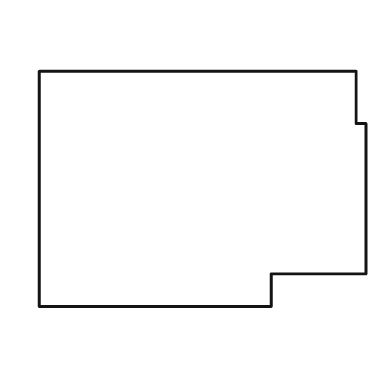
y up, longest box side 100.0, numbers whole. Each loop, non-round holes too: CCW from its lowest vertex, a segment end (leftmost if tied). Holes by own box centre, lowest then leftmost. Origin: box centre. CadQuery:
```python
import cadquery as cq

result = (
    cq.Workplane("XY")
    .moveTo(-50.0, -36.0)
    .lineTo(21.0, -36.0)
    .lineTo(21.0, -26.0)
    .lineTo(50.0, -26.0)
    .lineTo(50.0, 20.0)
    .lineTo(47.0, 20.0)
    .lineTo(47.0, 36.0)
    .lineTo(-50.0, 36.0)
    .close()
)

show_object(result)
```